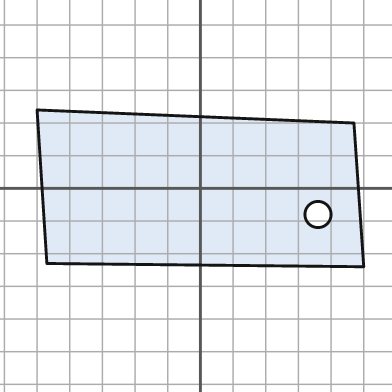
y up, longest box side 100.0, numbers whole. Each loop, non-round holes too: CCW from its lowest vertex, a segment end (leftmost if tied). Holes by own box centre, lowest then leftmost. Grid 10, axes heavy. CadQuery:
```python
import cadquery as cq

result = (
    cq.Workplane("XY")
    .moveTo(50.0, -24.0)
    .lineTo(47.0, 20.0)
    .lineTo(-50.0, 24.0)
    .lineTo(-47.0, -23.0)
    .close()
    .moveTo(36.0, -8.0)
    .circle(4.0)
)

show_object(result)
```